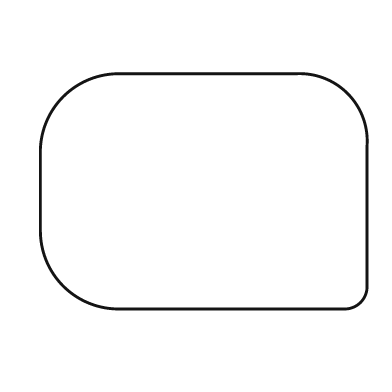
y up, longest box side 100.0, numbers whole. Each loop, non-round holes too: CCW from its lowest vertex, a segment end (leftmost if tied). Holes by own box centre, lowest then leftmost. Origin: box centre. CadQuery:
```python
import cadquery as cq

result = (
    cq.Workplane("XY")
    .moveTo(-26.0, -36.0)
    .lineTo(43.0, -36.0)
    .threePointArc((48.0, -34.0), (50.0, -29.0))
    .lineTo(50.0, 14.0)
    .threePointArc((44.0, 30.0), (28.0, 36.0))
    .lineTo(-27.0, 36.0)
    .threePointArc((-43.0, 29.0), (-50.0, 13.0))
    .lineTo(-50.0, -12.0)
    .threePointArc((-43.0, -29.0), (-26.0, -36.0))
    .close()
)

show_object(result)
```